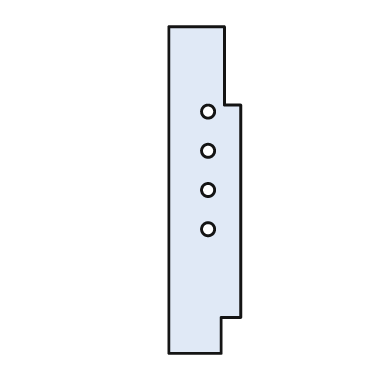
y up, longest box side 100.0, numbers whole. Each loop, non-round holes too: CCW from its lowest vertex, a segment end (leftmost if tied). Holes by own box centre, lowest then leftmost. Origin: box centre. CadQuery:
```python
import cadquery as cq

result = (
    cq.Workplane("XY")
    .moveTo(-11.0, -50.0)
    .lineTo(5.0, -50.0)
    .lineTo(5.0, -39.0)
    .lineTo(11.0, -39.0)
    .lineTo(11.0, 26.0)
    .lineTo(6.0, 26.0)
    .lineTo(6.0, 50.0)
    .lineTo(-11.0, 50.0)
    .close()
    .moveTo(1.0, -12.0)
    .circle(2.0)
    .moveTo(1.0, 0.0)
    .circle(2.0)
    .moveTo(1.0, 12.0)
    .circle(2.0)
    .moveTo(1.0, 24.0)
    .circle(2.0)
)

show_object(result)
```